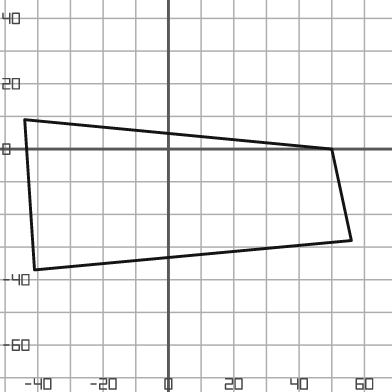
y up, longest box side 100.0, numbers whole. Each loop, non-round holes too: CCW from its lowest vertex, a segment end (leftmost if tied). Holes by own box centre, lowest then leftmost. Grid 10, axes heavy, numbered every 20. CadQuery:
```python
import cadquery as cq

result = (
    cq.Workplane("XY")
    .moveTo(-41.0, -37.0)
    .lineTo(56.0, -28.0)
    .lineTo(50.0, 0.0)
    .lineTo(-44.0, 9.0)
    .close()
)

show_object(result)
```